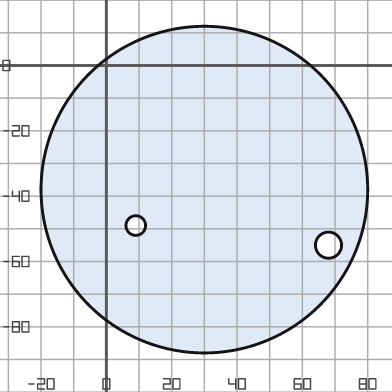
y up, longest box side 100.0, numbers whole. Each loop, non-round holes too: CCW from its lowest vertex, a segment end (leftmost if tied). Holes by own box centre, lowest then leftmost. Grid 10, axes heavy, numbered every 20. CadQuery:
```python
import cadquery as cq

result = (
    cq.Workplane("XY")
    .moveTo(30.0, -38.0)
    .circle(50.0)
    .moveTo(68.0, -55.0)
    .circle(4.0)
    .moveTo(9.0, -49.0)
    .circle(3.0)
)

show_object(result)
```